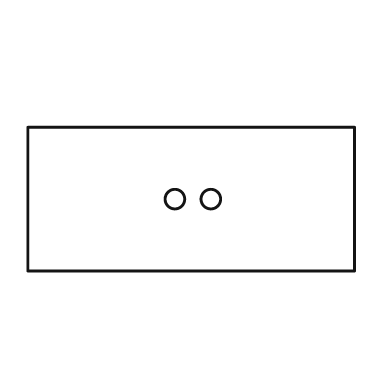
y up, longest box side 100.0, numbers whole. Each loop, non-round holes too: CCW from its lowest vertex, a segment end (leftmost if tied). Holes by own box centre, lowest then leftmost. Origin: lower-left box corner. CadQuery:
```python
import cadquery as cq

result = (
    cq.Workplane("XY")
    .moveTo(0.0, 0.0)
    .lineTo(100.0, 0.0)
    .lineTo(100.0, 44.0)
    .lineTo(0.0, 44.0)
    .close()
    .moveTo(45.0, 22.0)
    .circle(3.0)
    .moveTo(56.0, 22.0)
    .circle(3.0)
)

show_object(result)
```